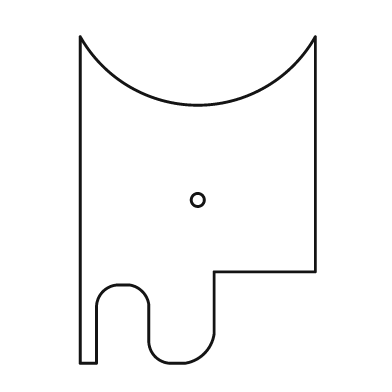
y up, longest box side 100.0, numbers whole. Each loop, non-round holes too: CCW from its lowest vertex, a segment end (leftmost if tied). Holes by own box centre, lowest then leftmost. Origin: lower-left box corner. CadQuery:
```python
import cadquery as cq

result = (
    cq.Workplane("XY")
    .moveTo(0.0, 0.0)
    .lineTo(5.0, 0.0)
    .lineTo(5.0, 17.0)
    .threePointArc((7.0, 22.0), (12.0, 24.0))
    .lineTo(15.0, 24.0)
    .threePointArc((19.0, 22.0), (21.0, 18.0))
    .lineTo(21.0, 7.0)
    .threePointArc((23.0, 2.0), (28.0, 0.0))
    .lineTo(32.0, 0.0)
    .threePointArc((38.0, 3.0), (41.0, 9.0))
    .lineTo(41.0, 28.0)
    .lineTo(72.0, 28.0)
    .lineTo(72.0, 100.0)
    .threePointArc((36.0, 79.0), (0.0, 100.0))
    .close()
    .moveTo(36.0, 50.0)
    .circle(2.0)
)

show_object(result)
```